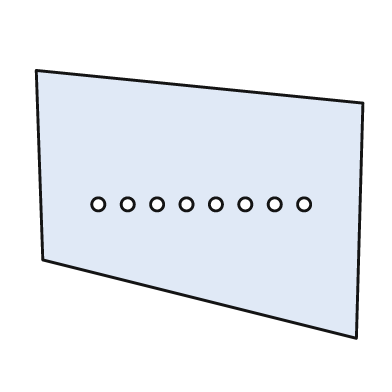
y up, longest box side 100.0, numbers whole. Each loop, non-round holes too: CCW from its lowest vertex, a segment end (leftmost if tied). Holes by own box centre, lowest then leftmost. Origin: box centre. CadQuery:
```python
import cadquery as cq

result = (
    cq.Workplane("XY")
    .moveTo(48.0, -41.0)
    .lineTo(50.0, 31.0)
    .lineTo(-50.0, 41.0)
    .lineTo(-48.0, -17.0)
    .close()
    .moveTo(-31.0, 0.0)
    .circle(2.0)
    .moveTo(-22.0, 0.0)
    .circle(2.0)
    .moveTo(-13.0, 0.0)
    .circle(2.0)
    .moveTo(-4.0, 0.0)
    .circle(2.0)
    .moveTo(5.0, 0.0)
    .circle(2.0)
    .moveTo(14.0, 0.0)
    .circle(2.0)
    .moveTo(23.0, 0.0)
    .circle(2.0)
    .moveTo(32.0, 0.0)
    .circle(2.0)
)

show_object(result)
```